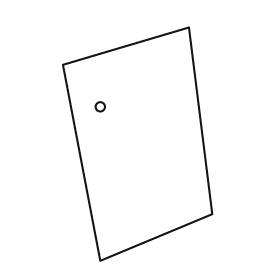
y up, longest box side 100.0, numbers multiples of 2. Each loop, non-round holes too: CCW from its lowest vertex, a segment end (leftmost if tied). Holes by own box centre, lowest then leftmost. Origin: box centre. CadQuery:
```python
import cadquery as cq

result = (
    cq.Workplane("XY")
    .moveTo(-16.0, -50.0)
    .lineTo(32.0, -30.0)
    .lineTo(22.0, 50.0)
    .lineTo(-32.0, 34.0)
    .close()
    .moveTo(-16.0, 16.0)
    .circle(2.0)
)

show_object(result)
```